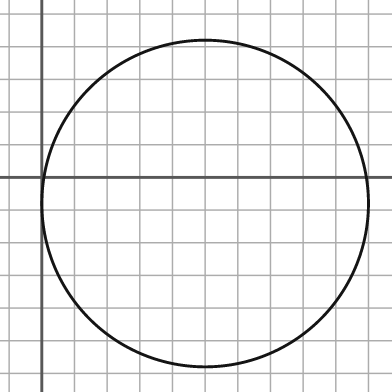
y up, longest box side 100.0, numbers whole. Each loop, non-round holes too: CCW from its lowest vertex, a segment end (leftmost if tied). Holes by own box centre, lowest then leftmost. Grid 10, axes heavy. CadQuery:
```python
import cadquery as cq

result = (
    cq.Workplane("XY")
    .moveTo(50.0, -8.0)
    .circle(50.0)
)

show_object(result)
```